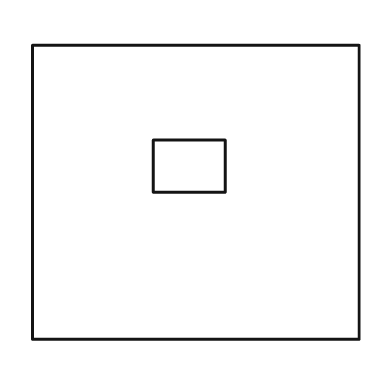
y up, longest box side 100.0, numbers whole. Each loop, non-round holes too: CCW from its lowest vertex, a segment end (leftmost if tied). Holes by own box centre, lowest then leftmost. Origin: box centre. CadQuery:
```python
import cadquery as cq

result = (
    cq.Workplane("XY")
    .moveTo(-50.0, -45.0)
    .lineTo(50.0, -45.0)
    .lineTo(50.0, 45.0)
    .lineTo(-50.0, 45.0)
    .close()
    .moveTo(-13.0, 0.0)
    .lineTo(9.0, 0.0)
    .lineTo(9.0, 16.0)
    .lineTo(-13.0, 16.0)
    .close()
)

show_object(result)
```